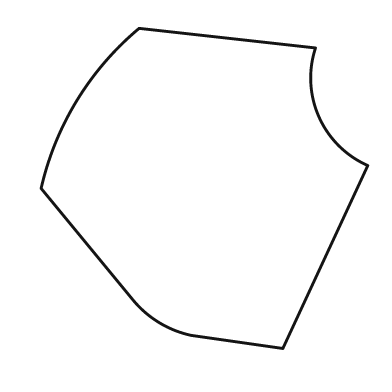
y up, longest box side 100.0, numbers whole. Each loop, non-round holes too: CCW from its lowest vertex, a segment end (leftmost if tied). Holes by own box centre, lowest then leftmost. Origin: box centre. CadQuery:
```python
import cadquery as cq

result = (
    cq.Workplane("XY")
    .moveTo(24.0, -49.0)
    .lineTo(50.0, 7.0)
    .threePointArc((35.0, 22.0), (34.0, 43.0))
    .lineTo(-20.0, 49.0)
    .threePointArc((-39.0, 27.0), (-50.0, 0.0))
    .lineTo(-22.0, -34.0)
    .threePointArc((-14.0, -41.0), (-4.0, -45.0))
    .close()
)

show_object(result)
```